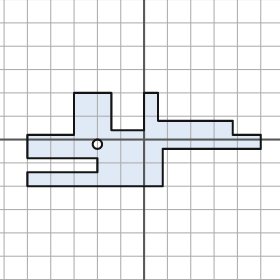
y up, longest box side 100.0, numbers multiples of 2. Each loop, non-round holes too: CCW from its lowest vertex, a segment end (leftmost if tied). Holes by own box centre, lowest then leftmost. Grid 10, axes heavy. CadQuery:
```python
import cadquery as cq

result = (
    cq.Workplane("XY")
    .moveTo(-50.0, -20.0)
    .lineTo(8.0, -20.0)
    .lineTo(8.0, -4.0)
    .lineTo(50.0, -4.0)
    .lineTo(50.0, 2.0)
    .lineTo(38.0, 2.0)
    .lineTo(38.0, 8.0)
    .lineTo(6.0, 8.0)
    .lineTo(6.0, 20.0)
    .lineTo(0.0, 20.0)
    .lineTo(0.0, 4.0)
    .lineTo(-14.0, 4.0)
    .lineTo(-14.0, 20.0)
    .lineTo(-30.0, 20.0)
    .lineTo(-30.0, 2.0)
    .lineTo(-50.0, 2.0)
    .lineTo(-50.0, -8.0)
    .lineTo(-20.0, -8.0)
    .lineTo(-20.0, -14.0)
    .lineTo(-50.0, -14.0)
    .close()
    .moveTo(-20.0, -2.0)
    .circle(2.0)
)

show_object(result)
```